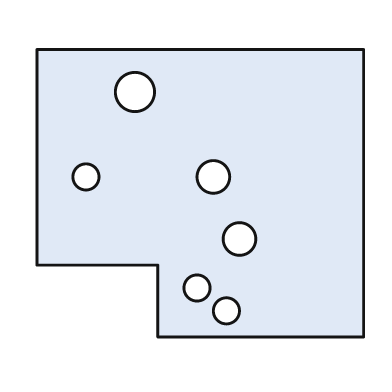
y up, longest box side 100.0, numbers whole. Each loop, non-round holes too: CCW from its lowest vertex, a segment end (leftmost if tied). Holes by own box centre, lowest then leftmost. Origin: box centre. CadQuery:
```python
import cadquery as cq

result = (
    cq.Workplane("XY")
    .moveTo(-13.0, -44.0)
    .lineTo(50.0, -44.0)
    .lineTo(50.0, 44.0)
    .lineTo(-50.0, 44.0)
    .lineTo(-50.0, -22.0)
    .lineTo(-13.0, -22.0)
    .close()
    .moveTo(8.0, -36.0)
    .circle(4.0)
    .moveTo(-1.0, -29.0)
    .circle(4.0)
    .moveTo(12.0, -14.0)
    .circle(5.0)
    .moveTo(-35.0, 5.0)
    .circle(4.0)
    .moveTo(4.0, 5.0)
    .circle(5.0)
    .moveTo(-20.0, 31.0)
    .circle(6.0)
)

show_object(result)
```